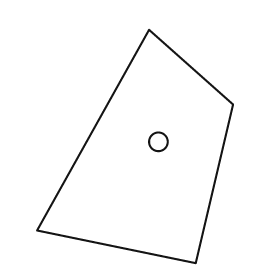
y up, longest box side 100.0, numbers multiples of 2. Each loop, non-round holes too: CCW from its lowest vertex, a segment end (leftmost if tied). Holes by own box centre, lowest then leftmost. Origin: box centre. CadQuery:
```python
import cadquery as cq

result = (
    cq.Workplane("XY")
    .moveTo(26.0, -50.0)
    .lineTo(42.0, 18.0)
    .lineTo(6.0, 50.0)
    .lineTo(-42.0, -36.0)
    .close()
    .moveTo(10.0, 2.0)
    .circle(4.0)
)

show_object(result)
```